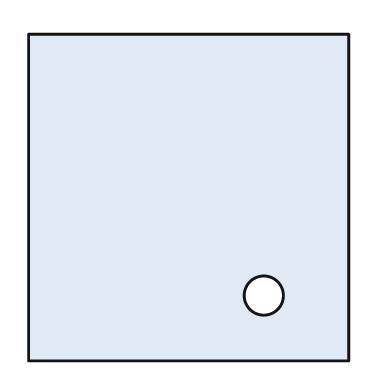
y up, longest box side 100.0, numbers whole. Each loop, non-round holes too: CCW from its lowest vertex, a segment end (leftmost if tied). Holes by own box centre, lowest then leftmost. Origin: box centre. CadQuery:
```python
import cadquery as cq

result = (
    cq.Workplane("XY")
    .moveTo(-49.0, -50.0)
    .lineTo(49.0, -50.0)
    .lineTo(49.0, 50.0)
    .lineTo(-49.0, 50.0)
    .close()
    .moveTo(23.0, -30.0)
    .circle(6.0)
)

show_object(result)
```